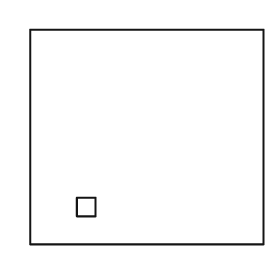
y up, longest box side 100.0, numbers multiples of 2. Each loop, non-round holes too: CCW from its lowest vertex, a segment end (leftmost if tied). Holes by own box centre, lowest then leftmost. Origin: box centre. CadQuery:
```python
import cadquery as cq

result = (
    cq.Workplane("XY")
    .moveTo(-50.0, -46.0)
    .lineTo(50.0, -46.0)
    .lineTo(50.0, 46.0)
    .lineTo(-50.0, 46.0)
    .close()
    .moveTo(-30.0, -34.0)
    .lineTo(-22.0, -34.0)
    .lineTo(-22.0, -26.0)
    .lineTo(-30.0, -26.0)
    .close()
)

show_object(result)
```